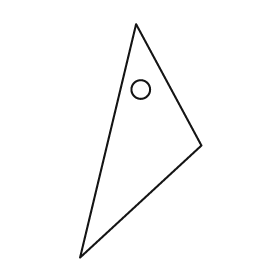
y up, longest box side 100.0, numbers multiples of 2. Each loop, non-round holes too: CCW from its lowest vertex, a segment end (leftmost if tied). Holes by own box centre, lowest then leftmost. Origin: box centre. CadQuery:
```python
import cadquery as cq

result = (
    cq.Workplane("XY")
    .moveTo(-26.0, -50.0)
    .lineTo(26.0, -2.0)
    .lineTo(-2.0, 50.0)
    .close()
    .moveTo(0.0, 22.0)
    .circle(4.0)
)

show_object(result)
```